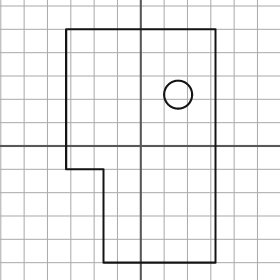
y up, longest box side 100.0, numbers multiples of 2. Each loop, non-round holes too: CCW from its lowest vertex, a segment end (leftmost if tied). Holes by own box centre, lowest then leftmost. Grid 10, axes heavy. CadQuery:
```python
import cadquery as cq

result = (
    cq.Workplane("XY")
    .moveTo(-16.0, -50.0)
    .lineTo(32.0, -50.0)
    .lineTo(32.0, 50.0)
    .lineTo(-32.0, 50.0)
    .lineTo(-32.0, -10.0)
    .lineTo(-16.0, -10.0)
    .close()
    .moveTo(16.0, 22.0)
    .circle(6.0)
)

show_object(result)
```